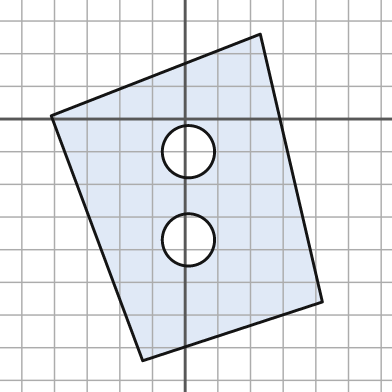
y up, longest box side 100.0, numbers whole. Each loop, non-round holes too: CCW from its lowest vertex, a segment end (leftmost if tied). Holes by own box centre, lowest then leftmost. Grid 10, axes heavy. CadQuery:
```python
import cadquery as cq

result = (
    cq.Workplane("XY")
    .moveTo(-13.0, -74.0)
    .lineTo(42.0, -56.0)
    .lineTo(23.0, 26.0)
    .lineTo(-41.0, 1.0)
    .close()
    .moveTo(1.0, -37.0)
    .circle(8.0)
    .moveTo(1.0, -10.0)
    .circle(8.0)
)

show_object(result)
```